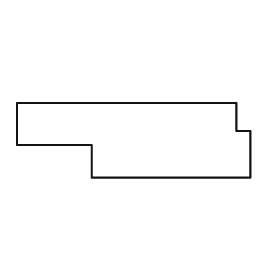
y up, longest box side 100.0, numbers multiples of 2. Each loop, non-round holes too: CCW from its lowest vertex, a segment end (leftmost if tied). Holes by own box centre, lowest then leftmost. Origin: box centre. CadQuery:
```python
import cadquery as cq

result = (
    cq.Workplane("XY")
    .moveTo(-18.0, -16.0)
    .lineTo(50.0, -16.0)
    .lineTo(50.0, 4.0)
    .lineTo(44.0, 4.0)
    .lineTo(44.0, 16.0)
    .lineTo(-50.0, 16.0)
    .lineTo(-50.0, -2.0)
    .lineTo(-18.0, -2.0)
    .close()
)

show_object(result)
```